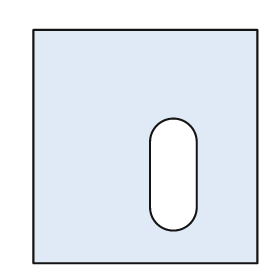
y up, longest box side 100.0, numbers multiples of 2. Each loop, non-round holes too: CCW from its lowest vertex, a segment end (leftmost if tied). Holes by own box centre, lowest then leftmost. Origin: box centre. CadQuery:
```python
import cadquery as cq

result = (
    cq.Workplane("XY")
    .moveTo(-48.0, -50.0)
    .lineTo(48.0, -50.0)
    .lineTo(48.0, 50.0)
    .lineTo(-48.0, 50.0)
    .close()
    .moveTo(2.0, -26.0)
    .threePointArc((12.0, -36.0), (22.0, -26.0))
    .lineTo(22.0, 2.0)
    .threePointArc((12.0, 12.0), (2.0, 2.0))
    .close()
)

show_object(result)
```